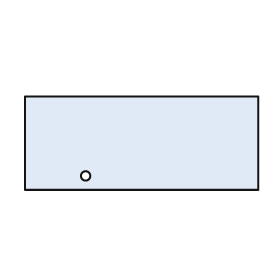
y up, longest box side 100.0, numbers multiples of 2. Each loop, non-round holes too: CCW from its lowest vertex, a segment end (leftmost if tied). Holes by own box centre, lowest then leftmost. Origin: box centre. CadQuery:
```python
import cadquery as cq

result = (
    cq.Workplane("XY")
    .moveTo(-50.0, -20.0)
    .lineTo(50.0, -20.0)
    .lineTo(50.0, 20.0)
    .lineTo(-50.0, 20.0)
    .close()
    .moveTo(-24.0, -14.0)
    .circle(2.0)
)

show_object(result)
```